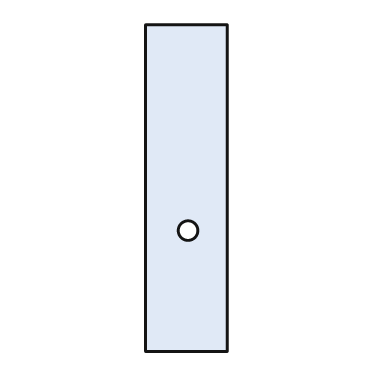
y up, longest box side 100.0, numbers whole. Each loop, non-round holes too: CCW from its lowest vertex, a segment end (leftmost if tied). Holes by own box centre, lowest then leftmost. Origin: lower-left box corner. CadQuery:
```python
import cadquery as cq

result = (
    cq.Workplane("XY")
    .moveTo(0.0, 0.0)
    .lineTo(25.0, 0.0)
    .lineTo(25.0, 100.0)
    .lineTo(0.0, 100.0)
    .close()
    .moveTo(13.0, 37.0)
    .circle(3.0)
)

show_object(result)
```